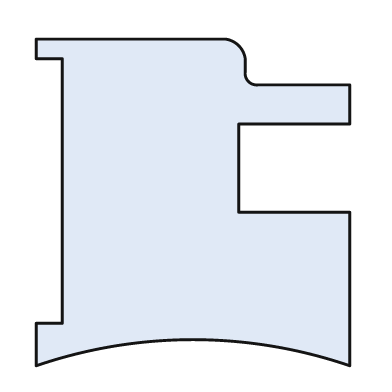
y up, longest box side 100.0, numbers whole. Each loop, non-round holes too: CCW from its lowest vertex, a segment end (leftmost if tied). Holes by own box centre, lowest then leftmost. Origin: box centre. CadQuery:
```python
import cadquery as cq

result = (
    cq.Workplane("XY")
    .moveTo(-48.0, -50.0)
    .threePointArc((0.0, -42.0), (48.0, -50.0))
    .lineTo(48.0, -3.0)
    .lineTo(14.0, -3.0)
    .lineTo(14.0, 24.0)
    .lineTo(48.0, 24.0)
    .lineTo(48.0, 36.0)
    .lineTo(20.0, 36.0)
    .threePointArc((17.0, 37.0), (16.0, 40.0))
    .lineTo(16.0, 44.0)
    .threePointArc((14.0, 48.0), (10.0, 50.0))
    .lineTo(-48.0, 50.0)
    .lineTo(-48.0, 44.0)
    .lineTo(-40.0, 44.0)
    .lineTo(-40.0, -37.0)
    .lineTo(-48.0, -37.0)
    .close()
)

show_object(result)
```